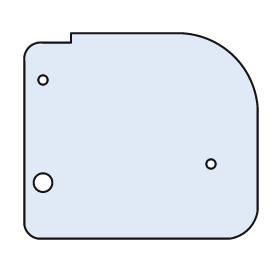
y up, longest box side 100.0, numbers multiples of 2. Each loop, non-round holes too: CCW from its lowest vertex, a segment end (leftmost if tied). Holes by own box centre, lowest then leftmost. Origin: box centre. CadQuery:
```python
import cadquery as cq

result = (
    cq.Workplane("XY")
    .moveTo(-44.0, -44.0)
    .lineTo(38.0, -44.0)
    .threePointArc((46.0, -40.0), (50.0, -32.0))
    .lineTo(50.0, 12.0)
    .threePointArc((40.0, 34.0), (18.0, 44.0))
    .lineTo(-30.0, 44.0)
    .lineTo(-30.0, 40.0)
    .lineTo(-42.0, 40.0)
    .threePointArc((-48.0, 38.0), (-50.0, 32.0))
    .lineTo(-50.0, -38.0)
    .threePointArc((-48.0, -42.0), (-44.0, -44.0))
    .close()
    .moveTo(-42.0, -20.0)
    .circle(4.0)
    .moveTo(30.0, -12.0)
    .circle(2.0)
    .moveTo(-42.0, 24.0)
    .circle(2.0)
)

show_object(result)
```